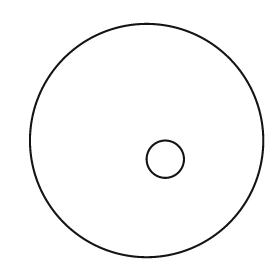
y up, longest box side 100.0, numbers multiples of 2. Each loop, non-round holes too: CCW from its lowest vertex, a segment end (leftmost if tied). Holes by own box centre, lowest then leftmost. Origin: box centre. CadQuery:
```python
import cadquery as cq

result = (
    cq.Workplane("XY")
    .moveTo(0.0, 0.0)
    .circle(50.0)
    .moveTo(8.0, -8.0)
    .circle(8.0)
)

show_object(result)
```